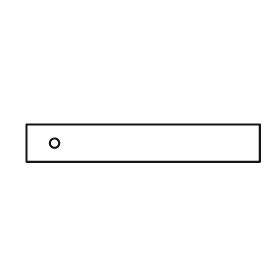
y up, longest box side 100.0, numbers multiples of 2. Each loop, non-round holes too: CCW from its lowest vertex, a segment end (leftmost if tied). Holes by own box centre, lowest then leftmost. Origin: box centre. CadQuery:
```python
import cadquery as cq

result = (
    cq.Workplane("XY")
    .moveTo(-50.0, -8.0)
    .lineTo(50.0, -8.0)
    .lineTo(50.0, 8.0)
    .lineTo(-50.0, 8.0)
    .close()
    .moveTo(-38.0, 0.0)
    .circle(2.0)
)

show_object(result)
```